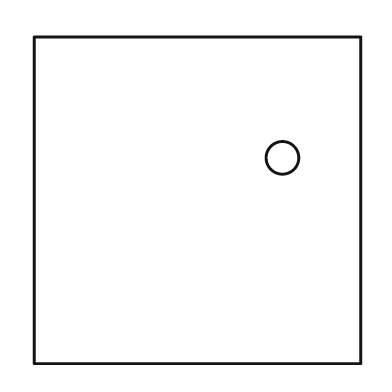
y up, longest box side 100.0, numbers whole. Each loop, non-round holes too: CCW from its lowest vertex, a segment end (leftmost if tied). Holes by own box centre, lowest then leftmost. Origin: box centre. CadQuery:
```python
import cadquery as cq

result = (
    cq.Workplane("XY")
    .moveTo(-50.0, -50.0)
    .lineTo(50.0, -50.0)
    .lineTo(50.0, 50.0)
    .lineTo(-50.0, 50.0)
    .close()
    .moveTo(26.0, 13.0)
    .circle(5.0)
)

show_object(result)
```